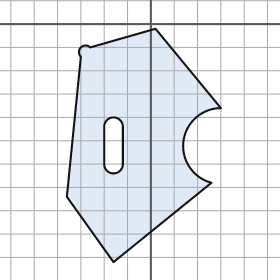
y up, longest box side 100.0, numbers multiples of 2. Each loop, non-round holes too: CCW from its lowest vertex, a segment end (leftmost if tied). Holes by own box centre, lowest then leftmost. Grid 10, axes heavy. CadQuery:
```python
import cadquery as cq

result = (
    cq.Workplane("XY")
    .moveTo(-16.0, -102.0)
    .lineTo(26.0, -68.0)
    .threePointArc((14.0, -50.0), (30.0, -36.0))
    .lineTo(2.0, -2.0)
    .lineTo(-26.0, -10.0)
    .threePointArc((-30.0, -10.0), (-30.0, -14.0))
    .lineTo(-36.0, -74.0)
    .close()
    .moveTo(-20.0, -60.0)
    .threePointArc((-16.0, -64.0), (-12.0, -60.0))
    .lineTo(-12.0, -44.0)
    .threePointArc((-16.0, -40.0), (-20.0, -44.0))
    .close()
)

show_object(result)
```